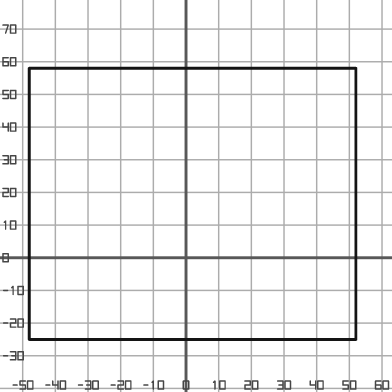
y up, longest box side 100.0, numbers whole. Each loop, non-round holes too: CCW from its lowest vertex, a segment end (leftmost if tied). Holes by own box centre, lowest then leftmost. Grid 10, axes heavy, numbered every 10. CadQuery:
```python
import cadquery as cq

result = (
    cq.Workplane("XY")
    .moveTo(-48.0, -25.0)
    .lineTo(52.0, -25.0)
    .lineTo(52.0, 58.0)
    .lineTo(-48.0, 58.0)
    .close()
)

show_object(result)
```